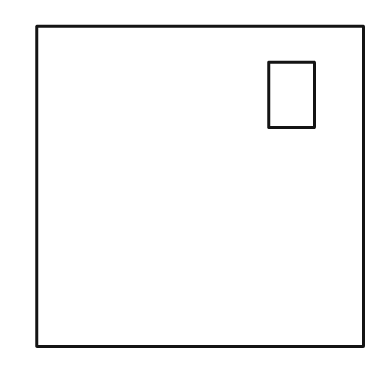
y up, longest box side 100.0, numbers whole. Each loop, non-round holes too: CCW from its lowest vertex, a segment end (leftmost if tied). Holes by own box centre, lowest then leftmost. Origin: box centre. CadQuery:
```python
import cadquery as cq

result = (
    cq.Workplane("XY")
    .moveTo(-50.0, -49.0)
    .lineTo(50.0, -49.0)
    .lineTo(50.0, 49.0)
    .lineTo(-50.0, 49.0)
    .close()
    .moveTo(21.0, 18.0)
    .lineTo(35.0, 18.0)
    .lineTo(35.0, 38.0)
    .lineTo(21.0, 38.0)
    .close()
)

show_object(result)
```